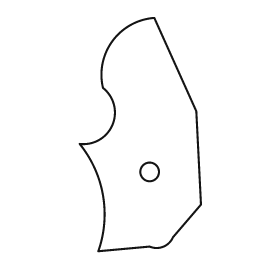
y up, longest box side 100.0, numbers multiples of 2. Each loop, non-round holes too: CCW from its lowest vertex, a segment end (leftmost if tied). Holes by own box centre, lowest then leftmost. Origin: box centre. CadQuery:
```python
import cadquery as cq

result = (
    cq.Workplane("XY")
    .moveTo(-18.0, -50.0)
    .lineTo(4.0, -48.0)
    .threePointArc((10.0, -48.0), (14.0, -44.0))
    .lineTo(26.0, -30.0)
    .lineTo(24.0, 10.0)
    .lineTo(6.0, 50.0)
    .threePointArc((-12.0, 40.0), (-16.0, 20.0))
    .threePointArc((-12.0, 4.0), (-26.0, -4.0))
    .threePointArc((-16.0, -26.0), (-18.0, -50.0))
    .close()
    .moveTo(4.0, -16.0)
    .circle(4.0)
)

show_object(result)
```